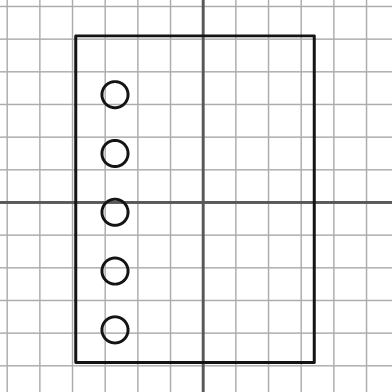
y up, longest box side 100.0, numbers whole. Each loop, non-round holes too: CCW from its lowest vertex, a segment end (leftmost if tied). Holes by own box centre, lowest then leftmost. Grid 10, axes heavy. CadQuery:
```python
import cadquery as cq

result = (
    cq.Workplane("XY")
    .moveTo(-39.0, -49.0)
    .lineTo(34.0, -49.0)
    .lineTo(34.0, 51.0)
    .lineTo(-39.0, 51.0)
    .close()
    .moveTo(-27.0, -39.0)
    .circle(4.0)
    .moveTo(-27.0, -21.0)
    .circle(4.0)
    .moveTo(-27.0, -3.0)
    .circle(4.0)
    .moveTo(-27.0, 15.0)
    .circle(4.0)
    .moveTo(-27.0, 33.0)
    .circle(4.0)
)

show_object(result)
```